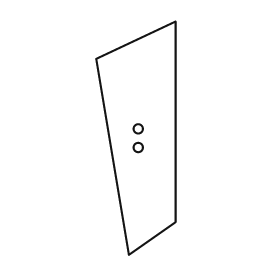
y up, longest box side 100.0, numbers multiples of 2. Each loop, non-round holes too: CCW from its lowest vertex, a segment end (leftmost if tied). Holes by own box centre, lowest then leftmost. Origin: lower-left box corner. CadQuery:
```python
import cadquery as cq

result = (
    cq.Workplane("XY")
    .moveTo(14.0, 0.0)
    .lineTo(34.0, 14.0)
    .lineTo(34.0, 100.0)
    .lineTo(0.0, 84.0)
    .close()
    .moveTo(18.0, 46.0)
    .circle(2.0)
    .moveTo(18.0, 54.0)
    .circle(2.0)
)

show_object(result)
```